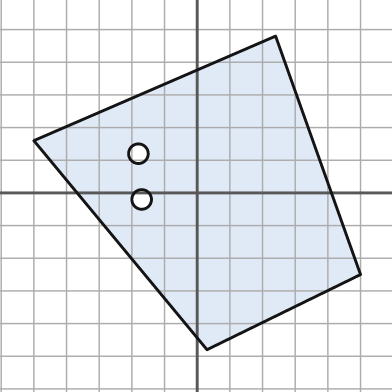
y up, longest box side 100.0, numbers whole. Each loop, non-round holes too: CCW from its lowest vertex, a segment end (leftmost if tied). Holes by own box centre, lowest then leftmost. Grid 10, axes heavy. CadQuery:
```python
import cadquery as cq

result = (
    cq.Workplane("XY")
    .moveTo(3.0, -48.0)
    .lineTo(50.0, -25.0)
    .lineTo(24.0, 48.0)
    .lineTo(-50.0, 16.0)
    .close()
    .moveTo(-17.0, -2.0)
    .circle(3.0)
    .moveTo(-18.0, 12.0)
    .circle(3.0)
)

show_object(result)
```